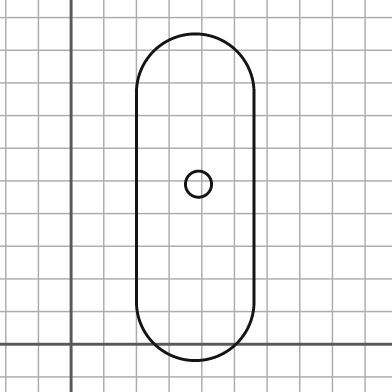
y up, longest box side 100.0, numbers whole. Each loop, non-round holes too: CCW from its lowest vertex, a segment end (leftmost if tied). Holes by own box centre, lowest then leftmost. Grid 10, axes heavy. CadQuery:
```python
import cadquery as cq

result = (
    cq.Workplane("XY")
    .moveTo(20.0, 13.0)
    .threePointArc((38.0, -5.0), (56.0, 13.0))
    .lineTo(56.0, 77.0)
    .threePointArc((38.0, 95.0), (20.0, 77.0))
    .close()
    .moveTo(39.0, 49.0)
    .circle(4.0)
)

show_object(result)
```